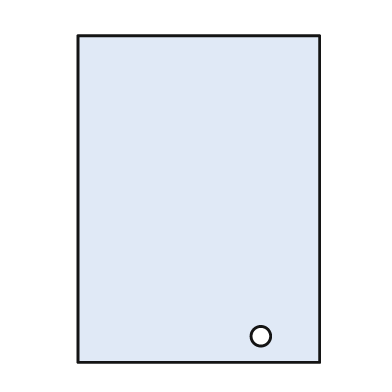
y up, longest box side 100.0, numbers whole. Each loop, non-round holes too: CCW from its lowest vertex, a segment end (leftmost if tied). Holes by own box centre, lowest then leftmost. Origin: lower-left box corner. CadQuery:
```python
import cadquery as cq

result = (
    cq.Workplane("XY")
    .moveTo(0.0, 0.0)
    .lineTo(74.0, 0.0)
    .lineTo(74.0, 100.0)
    .lineTo(0.0, 100.0)
    .close()
    .moveTo(56.0, 8.0)
    .circle(3.0)
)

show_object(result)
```